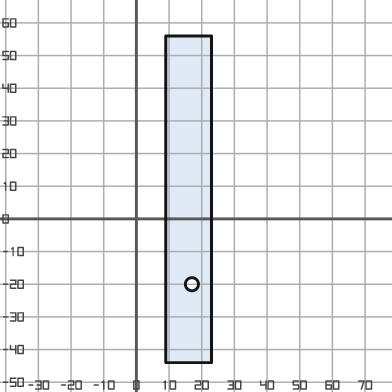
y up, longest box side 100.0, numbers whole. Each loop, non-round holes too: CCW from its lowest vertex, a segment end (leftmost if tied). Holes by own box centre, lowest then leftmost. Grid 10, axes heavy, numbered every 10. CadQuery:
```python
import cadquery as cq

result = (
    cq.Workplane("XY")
    .moveTo(9.0, -44.0)
    .lineTo(23.0, -44.0)
    .lineTo(23.0, 56.0)
    .lineTo(9.0, 56.0)
    .close()
    .moveTo(17.0, -20.0)
    .circle(2.0)
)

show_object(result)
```